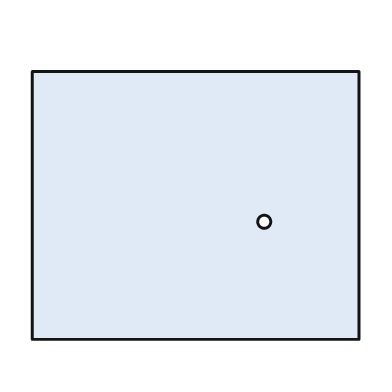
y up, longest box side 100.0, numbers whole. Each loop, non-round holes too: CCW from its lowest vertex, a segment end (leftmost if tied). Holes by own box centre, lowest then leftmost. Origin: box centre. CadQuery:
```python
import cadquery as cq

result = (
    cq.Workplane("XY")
    .moveTo(-50.0, -41.0)
    .lineTo(50.0, -41.0)
    .lineTo(50.0, 41.0)
    .lineTo(-50.0, 41.0)
    .close()
    .moveTo(21.0, -5.0)
    .circle(2.0)
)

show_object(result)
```